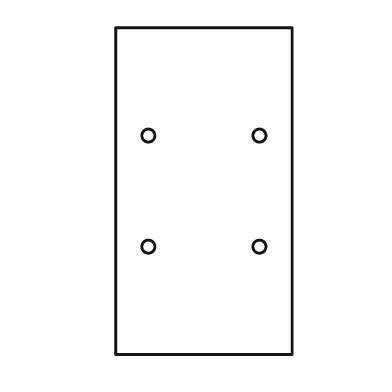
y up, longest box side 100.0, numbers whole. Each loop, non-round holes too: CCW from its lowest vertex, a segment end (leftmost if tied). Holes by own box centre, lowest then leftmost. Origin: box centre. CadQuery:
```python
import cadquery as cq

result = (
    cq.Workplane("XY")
    .moveTo(-27.0, -50.0)
    .lineTo(27.0, -50.0)
    .lineTo(27.0, 50.0)
    .lineTo(-27.0, 50.0)
    .close()
    .moveTo(-17.0, -17.0)
    .circle(2.0)
    .moveTo(17.0, -17.0)
    .circle(2.0)
    .moveTo(-17.0, 17.0)
    .circle(2.0)
    .moveTo(17.0, 17.0)
    .circle(2.0)
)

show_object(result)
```